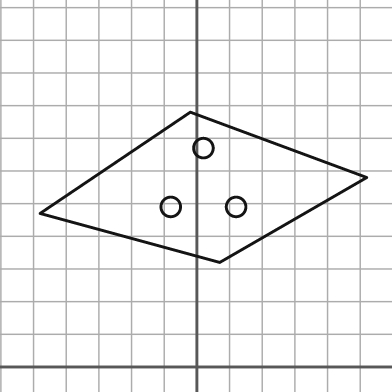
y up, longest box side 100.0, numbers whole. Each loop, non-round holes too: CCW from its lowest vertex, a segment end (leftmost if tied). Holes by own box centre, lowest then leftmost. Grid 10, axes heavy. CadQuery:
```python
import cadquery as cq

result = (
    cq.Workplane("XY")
    .moveTo(7.0, 32.0)
    .lineTo(52.0, 58.0)
    .lineTo(-2.0, 78.0)
    .lineTo(-48.0, 47.0)
    .close()
    .moveTo(-8.0, 49.0)
    .circle(3.0)
    .moveTo(12.0, 49.0)
    .circle(3.0)
    .moveTo(2.0, 67.0)
    .circle(3.0)
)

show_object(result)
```